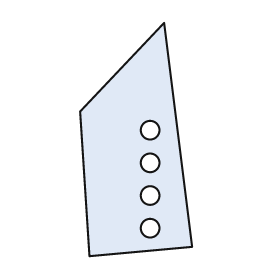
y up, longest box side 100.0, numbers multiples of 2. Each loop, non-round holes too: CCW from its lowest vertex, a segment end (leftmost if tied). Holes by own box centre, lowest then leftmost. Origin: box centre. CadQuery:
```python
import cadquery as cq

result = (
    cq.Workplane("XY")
    .moveTo(-20.0, -50.0)
    .lineTo(24.0, -46.0)
    .lineTo(12.0, 50.0)
    .lineTo(-24.0, 12.0)
    .close()
    .moveTo(6.0, -38.0)
    .circle(4.0)
    .moveTo(6.0, -24.0)
    .circle(4.0)
    .moveTo(6.0, -10.0)
    .circle(4.0)
    .moveTo(6.0, 4.0)
    .circle(4.0)
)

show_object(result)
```